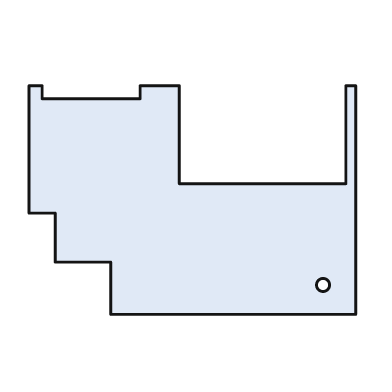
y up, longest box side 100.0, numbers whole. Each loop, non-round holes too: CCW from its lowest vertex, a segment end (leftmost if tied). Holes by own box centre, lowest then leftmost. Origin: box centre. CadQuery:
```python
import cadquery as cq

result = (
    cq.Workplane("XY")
    .moveTo(-25.0, -35.0)
    .lineTo(50.0, -35.0)
    .lineTo(50.0, 35.0)
    .lineTo(47.0, 35.0)
    .lineTo(47.0, 5.0)
    .lineTo(-4.0, 5.0)
    .lineTo(-4.0, 35.0)
    .lineTo(-16.0, 35.0)
    .lineTo(-16.0, 31.0)
    .lineTo(-46.0, 31.0)
    .lineTo(-46.0, 35.0)
    .lineTo(-50.0, 35.0)
    .lineTo(-50.0, -4.0)
    .lineTo(-42.0, -4.0)
    .lineTo(-42.0, -19.0)
    .lineTo(-25.0, -19.0)
    .close()
    .moveTo(40.0, -26.0)
    .circle(2.0)
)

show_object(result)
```